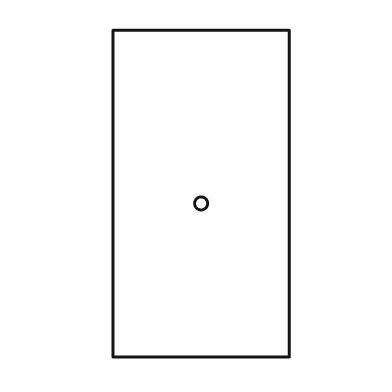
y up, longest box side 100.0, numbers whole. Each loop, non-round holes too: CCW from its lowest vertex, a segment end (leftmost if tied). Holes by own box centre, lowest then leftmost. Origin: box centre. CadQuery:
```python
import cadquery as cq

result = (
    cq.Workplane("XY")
    .moveTo(-27.0, -50.0)
    .lineTo(27.0, -50.0)
    .lineTo(27.0, 50.0)
    .lineTo(-27.0, 50.0)
    .close()
    .moveTo(0.0, -3.0)
    .circle(2.0)
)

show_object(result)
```